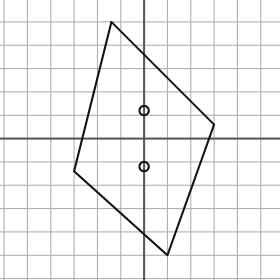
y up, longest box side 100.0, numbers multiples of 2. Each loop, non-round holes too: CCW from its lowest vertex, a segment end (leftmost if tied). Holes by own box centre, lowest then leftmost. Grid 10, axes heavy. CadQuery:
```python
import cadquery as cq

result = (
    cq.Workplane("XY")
    .moveTo(10.0, -50.0)
    .lineTo(30.0, 6.0)
    .lineTo(-14.0, 50.0)
    .lineTo(-30.0, -14.0)
    .close()
    .moveTo(0.0, -12.0)
    .circle(2.0)
    .moveTo(0.0, 12.0)
    .circle(2.0)
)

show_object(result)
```